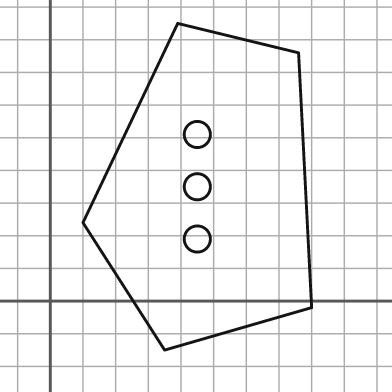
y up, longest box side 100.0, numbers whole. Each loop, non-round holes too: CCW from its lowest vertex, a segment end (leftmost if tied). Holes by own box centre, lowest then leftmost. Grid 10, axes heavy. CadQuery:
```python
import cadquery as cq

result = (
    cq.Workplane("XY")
    .moveTo(35.0, -15.0)
    .lineTo(80.0, -2.0)
    .lineTo(76.0, 76.0)
    .lineTo(39.0, 85.0)
    .lineTo(10.0, 24.0)
    .close()
    .moveTo(45.0, 19.0)
    .circle(4.0)
    .moveTo(45.0, 35.0)
    .circle(4.0)
    .moveTo(45.0, 51.0)
    .circle(4.0)
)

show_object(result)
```